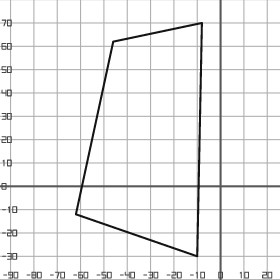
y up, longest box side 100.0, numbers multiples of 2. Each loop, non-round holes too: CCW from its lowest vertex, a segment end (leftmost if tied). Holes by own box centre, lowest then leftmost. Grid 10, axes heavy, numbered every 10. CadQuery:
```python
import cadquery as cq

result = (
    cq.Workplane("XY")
    .moveTo(-10.0, -30.0)
    .lineTo(-8.0, 70.0)
    .lineTo(-46.0, 62.0)
    .lineTo(-62.0, -12.0)
    .close()
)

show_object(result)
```